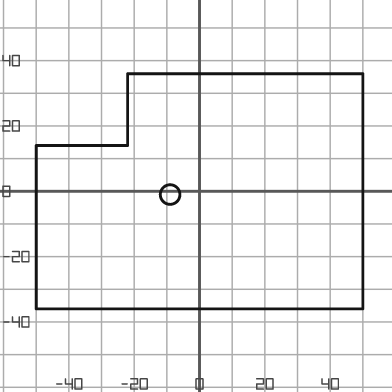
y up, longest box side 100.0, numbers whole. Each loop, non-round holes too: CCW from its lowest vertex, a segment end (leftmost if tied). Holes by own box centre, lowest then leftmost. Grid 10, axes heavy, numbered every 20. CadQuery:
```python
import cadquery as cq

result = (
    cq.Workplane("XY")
    .moveTo(-50.0, -36.0)
    .lineTo(50.0, -36.0)
    .lineTo(50.0, 36.0)
    .lineTo(-22.0, 36.0)
    .lineTo(-22.0, 14.0)
    .lineTo(-50.0, 14.0)
    .close()
    .moveTo(-9.0, -1.0)
    .circle(3.0)
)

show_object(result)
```